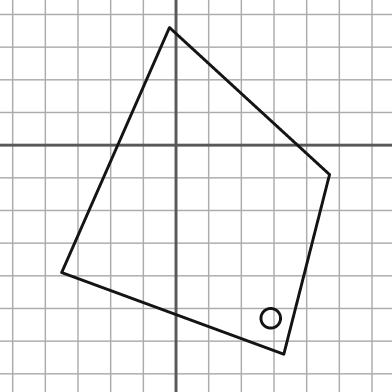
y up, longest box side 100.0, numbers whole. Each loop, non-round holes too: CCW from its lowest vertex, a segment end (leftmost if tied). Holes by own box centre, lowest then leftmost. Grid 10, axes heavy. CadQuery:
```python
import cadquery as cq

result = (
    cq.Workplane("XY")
    .moveTo(33.0, -64.0)
    .lineTo(47.0, -9.0)
    .lineTo(-2.0, 36.0)
    .lineTo(-35.0, -39.0)
    .close()
    .moveTo(29.0, -53.0)
    .circle(3.0)
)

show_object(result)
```